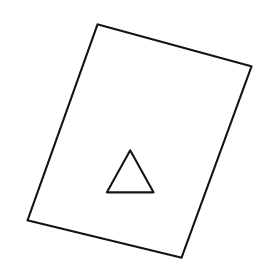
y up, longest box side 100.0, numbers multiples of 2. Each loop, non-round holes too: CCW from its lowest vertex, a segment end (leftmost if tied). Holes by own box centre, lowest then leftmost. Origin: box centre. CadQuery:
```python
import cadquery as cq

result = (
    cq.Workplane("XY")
    .moveTo(18.0, -50.0)
    .lineTo(48.0, 32.0)
    .lineTo(-18.0, 50.0)
    .lineTo(-48.0, -34.0)
    .close()
    .moveTo(-14.0, -22.0)
    .lineTo(6.0, -22.0)
    .lineTo(-4.0, -4.0)
    .close()
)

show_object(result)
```